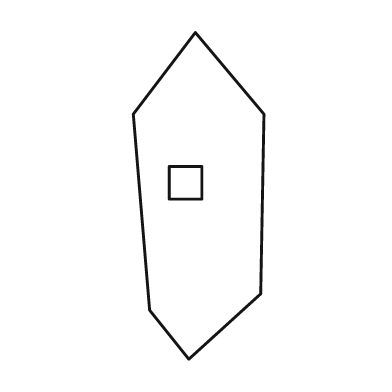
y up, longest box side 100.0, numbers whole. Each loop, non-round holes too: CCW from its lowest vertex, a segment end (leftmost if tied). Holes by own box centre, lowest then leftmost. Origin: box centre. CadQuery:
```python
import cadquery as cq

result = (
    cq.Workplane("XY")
    .moveTo(-3.0, -50.0)
    .lineTo(19.0, -30.0)
    .lineTo(20.0, 25.0)
    .lineTo(-1.0, 50.0)
    .lineTo(-20.0, 25.0)
    .lineTo(-15.0, -35.0)
    .close()
    .moveTo(-9.0, -1.0)
    .lineTo(1.0, -1.0)
    .lineTo(1.0, 9.0)
    .lineTo(-9.0, 9.0)
    .close()
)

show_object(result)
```